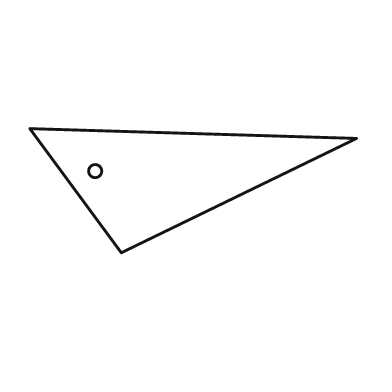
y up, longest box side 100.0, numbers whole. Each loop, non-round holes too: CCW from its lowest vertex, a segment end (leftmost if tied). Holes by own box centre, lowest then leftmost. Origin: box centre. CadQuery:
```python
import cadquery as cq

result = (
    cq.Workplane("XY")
    .moveTo(-22.0, -19.0)
    .lineTo(50.0, 16.0)
    .lineTo(-50.0, 19.0)
    .close()
    .moveTo(-30.0, 6.0)
    .circle(2.0)
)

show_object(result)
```